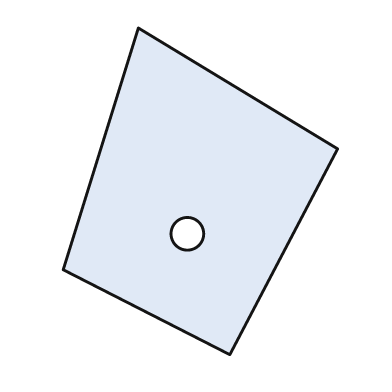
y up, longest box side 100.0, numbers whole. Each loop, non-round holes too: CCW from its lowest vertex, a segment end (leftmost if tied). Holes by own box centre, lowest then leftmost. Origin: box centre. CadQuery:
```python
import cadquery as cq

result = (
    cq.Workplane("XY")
    .moveTo(9.0, -50.0)
    .lineTo(42.0, 13.0)
    .lineTo(-19.0, 50.0)
    .lineTo(-42.0, -24.0)
    .close()
    .moveTo(-4.0, -13.0)
    .circle(5.0)
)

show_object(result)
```